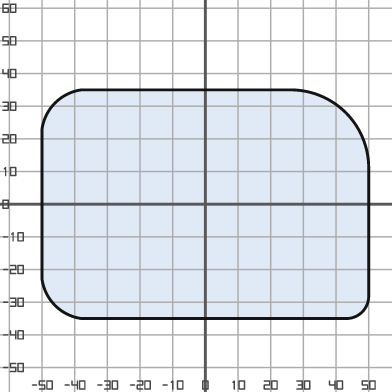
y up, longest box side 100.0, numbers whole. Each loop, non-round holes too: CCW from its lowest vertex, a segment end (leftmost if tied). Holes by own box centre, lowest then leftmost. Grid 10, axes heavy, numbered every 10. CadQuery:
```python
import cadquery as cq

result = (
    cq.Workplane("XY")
    .moveTo(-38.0, -35.0)
    .lineTo(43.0, -35.0)
    .threePointArc((48.0, -33.0), (50.0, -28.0))
    .lineTo(50.0, 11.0)
    .threePointArc((43.0, 28.0), (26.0, 35.0))
    .lineTo(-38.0, 35.0)
    .threePointArc((-46.0, 31.0), (-50.0, 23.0))
    .lineTo(-50.0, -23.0)
    .threePointArc((-46.0, -31.0), (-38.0, -35.0))
    .close()
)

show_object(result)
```